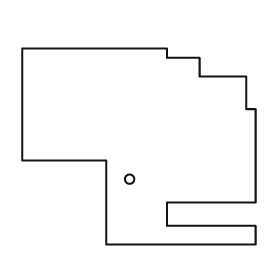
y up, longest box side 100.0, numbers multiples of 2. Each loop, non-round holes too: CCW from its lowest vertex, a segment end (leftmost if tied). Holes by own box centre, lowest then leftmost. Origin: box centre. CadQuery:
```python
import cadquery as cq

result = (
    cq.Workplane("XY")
    .moveTo(-14.0, -42.0)
    .lineTo(50.0, -42.0)
    .lineTo(50.0, -34.0)
    .lineTo(12.0, -34.0)
    .lineTo(12.0, -24.0)
    .lineTo(50.0, -24.0)
    .lineTo(50.0, 16.0)
    .lineTo(46.0, 16.0)
    .lineTo(46.0, 30.0)
    .lineTo(26.0, 30.0)
    .lineTo(26.0, 38.0)
    .lineTo(12.0, 38.0)
    .lineTo(12.0, 42.0)
    .lineTo(-50.0, 42.0)
    .lineTo(-50.0, -6.0)
    .lineTo(-14.0, -6.0)
    .close()
    .moveTo(-4.0, -14.0)
    .circle(2.0)
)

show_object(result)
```